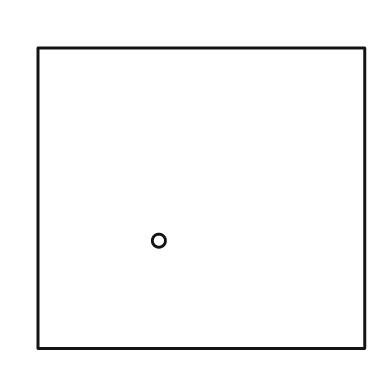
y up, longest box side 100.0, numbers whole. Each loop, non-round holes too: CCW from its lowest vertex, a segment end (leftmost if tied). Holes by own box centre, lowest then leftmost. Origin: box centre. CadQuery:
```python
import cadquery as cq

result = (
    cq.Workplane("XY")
    .moveTo(-50.0, -46.0)
    .lineTo(50.0, -46.0)
    .lineTo(50.0, 46.0)
    .lineTo(-50.0, 46.0)
    .close()
    .moveTo(-13.0, -13.0)
    .circle(2.0)
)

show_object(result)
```